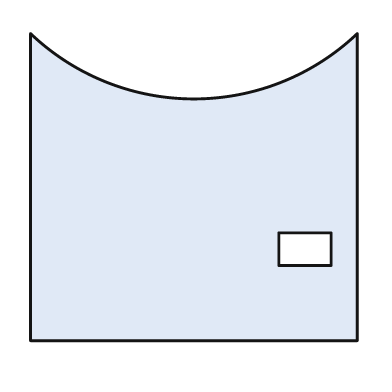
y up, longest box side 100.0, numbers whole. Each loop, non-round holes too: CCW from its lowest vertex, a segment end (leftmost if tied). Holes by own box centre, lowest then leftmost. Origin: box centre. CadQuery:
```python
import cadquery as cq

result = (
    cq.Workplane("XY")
    .moveTo(-50.0, -47.0)
    .lineTo(50.0, -47.0)
    .lineTo(50.0, 47.0)
    .threePointArc((0.0, 27.0), (-50.0, 47.0))
    .close()
    .moveTo(26.0, -24.0)
    .lineTo(42.0, -24.0)
    .lineTo(42.0, -14.0)
    .lineTo(26.0, -14.0)
    .close()
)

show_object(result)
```